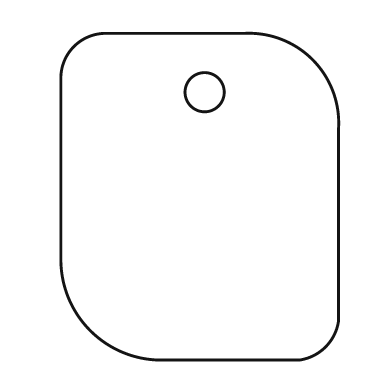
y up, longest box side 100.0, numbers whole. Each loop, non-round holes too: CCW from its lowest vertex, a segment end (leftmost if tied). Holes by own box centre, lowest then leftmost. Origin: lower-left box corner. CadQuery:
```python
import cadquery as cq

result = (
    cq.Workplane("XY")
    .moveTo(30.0, 0.0)
    .lineTo(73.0, 0.0)
    .threePointArc((81.0, 4.0), (85.0, 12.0))
    .lineTo(85.0, 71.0)
    .threePointArc((77.0, 92.0), (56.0, 100.0))
    .lineTo(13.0, 100.0)
    .threePointArc((4.0, 96.0), (0.0, 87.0))
    .lineTo(0.0, 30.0)
    .threePointArc((9.0, 9.0), (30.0, 0.0))
    .close()
    .moveTo(44.0, 82.0)
    .circle(6.0)
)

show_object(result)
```